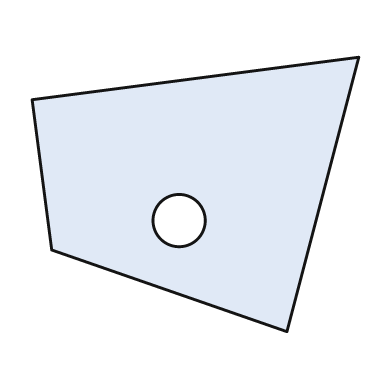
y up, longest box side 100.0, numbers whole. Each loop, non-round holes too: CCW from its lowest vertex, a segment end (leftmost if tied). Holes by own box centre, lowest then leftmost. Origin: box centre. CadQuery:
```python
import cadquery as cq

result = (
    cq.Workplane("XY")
    .moveTo(28.0, -42.0)
    .lineTo(50.0, 42.0)
    .lineTo(-50.0, 29.0)
    .lineTo(-44.0, -17.0)
    .close()
    .moveTo(-5.0, -8.0)
    .circle(8.0)
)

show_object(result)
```